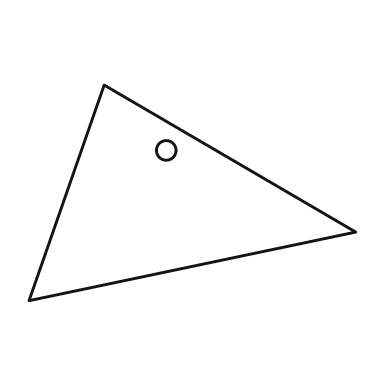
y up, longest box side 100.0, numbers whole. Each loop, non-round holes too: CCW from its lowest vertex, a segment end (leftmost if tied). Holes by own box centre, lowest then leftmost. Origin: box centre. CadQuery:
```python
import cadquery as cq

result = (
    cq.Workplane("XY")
    .moveTo(-50.0, -33.0)
    .lineTo(50.0, -12.0)
    .lineTo(-27.0, 33.0)
    .close()
    .moveTo(-8.0, 13.0)
    .circle(3.0)
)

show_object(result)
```